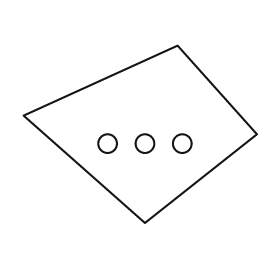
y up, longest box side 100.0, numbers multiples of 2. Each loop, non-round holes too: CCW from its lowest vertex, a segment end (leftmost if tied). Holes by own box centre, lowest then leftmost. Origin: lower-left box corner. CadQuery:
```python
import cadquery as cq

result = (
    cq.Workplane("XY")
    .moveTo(52.0, 0.0)
    .lineTo(100.0, 38.0)
    .lineTo(66.0, 76.0)
    .lineTo(0.0, 46.0)
    .close()
    .moveTo(36.0, 34.0)
    .circle(4.0)
    .moveTo(52.0, 34.0)
    .circle(4.0)
    .moveTo(68.0, 34.0)
    .circle(4.0)
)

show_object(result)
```